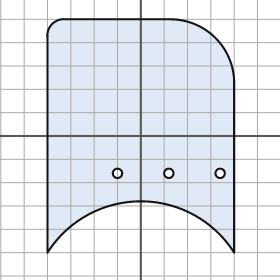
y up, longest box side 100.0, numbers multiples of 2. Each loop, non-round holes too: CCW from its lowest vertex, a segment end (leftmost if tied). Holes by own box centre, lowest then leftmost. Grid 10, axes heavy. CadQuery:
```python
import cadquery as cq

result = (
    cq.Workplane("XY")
    .moveTo(-40.0, -50.0)
    .threePointArc((0.0, -28.0), (40.0, -50.0))
    .lineTo(40.0, 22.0)
    .threePointArc((32.0, 42.0), (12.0, 50.0))
    .lineTo(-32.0, 50.0)
    .threePointArc((-38.0, 48.0), (-40.0, 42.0))
    .close()
    .moveTo(-10.0, -16.0)
    .circle(2.0)
    .moveTo(12.0, -16.0)
    .circle(2.0)
    .moveTo(34.0, -16.0)
    .circle(2.0)
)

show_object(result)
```